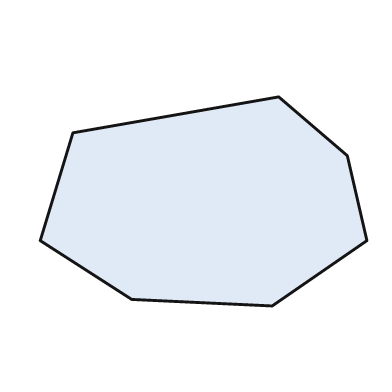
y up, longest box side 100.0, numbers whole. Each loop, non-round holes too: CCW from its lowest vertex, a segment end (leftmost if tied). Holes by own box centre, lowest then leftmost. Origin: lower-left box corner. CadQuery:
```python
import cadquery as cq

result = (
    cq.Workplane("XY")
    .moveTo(71.0, 0.0)
    .lineTo(100.0, 20.0)
    .lineTo(94.0, 46.0)
    .lineTo(73.0, 64.0)
    .lineTo(10.0, 53.0)
    .lineTo(0.0, 20.0)
    .lineTo(28.0, 2.0)
    .close()
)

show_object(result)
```